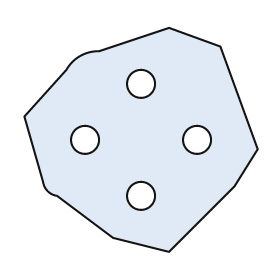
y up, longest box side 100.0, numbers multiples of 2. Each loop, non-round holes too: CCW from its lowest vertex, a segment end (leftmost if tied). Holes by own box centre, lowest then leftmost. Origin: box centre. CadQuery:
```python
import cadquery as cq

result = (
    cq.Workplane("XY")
    .moveTo(12.0, -48.0)
    .lineTo(40.0, -20.0)
    .lineTo(50.0, -4.0)
    .lineTo(34.0, 40.0)
    .lineTo(12.0, 48.0)
    .lineTo(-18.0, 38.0)
    .threePointArc((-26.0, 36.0), (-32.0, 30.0))
    .lineTo(-50.0, 10.0)
    .lineTo(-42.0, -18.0)
    .threePointArc((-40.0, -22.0), (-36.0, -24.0))
    .lineTo(-12.0, -42.0)
    .close()
    .moveTo(0.0, -24.0)
    .circle(6.0)
    .moveTo(-24.0, 0.0)
    .circle(6.0)
    .moveTo(24.0, 0.0)
    .circle(6.0)
    .moveTo(0.0, 24.0)
    .circle(6.0)
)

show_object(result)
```